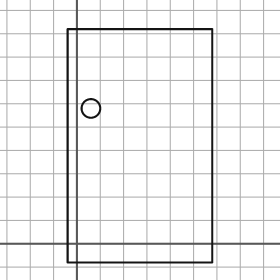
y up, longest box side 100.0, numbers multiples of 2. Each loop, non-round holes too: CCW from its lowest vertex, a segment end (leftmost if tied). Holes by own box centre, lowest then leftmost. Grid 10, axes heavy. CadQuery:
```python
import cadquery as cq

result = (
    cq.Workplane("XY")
    .moveTo(-4.0, -8.0)
    .lineTo(58.0, -8.0)
    .lineTo(58.0, 92.0)
    .lineTo(-4.0, 92.0)
    .close()
    .moveTo(6.0, 58.0)
    .circle(4.0)
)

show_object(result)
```